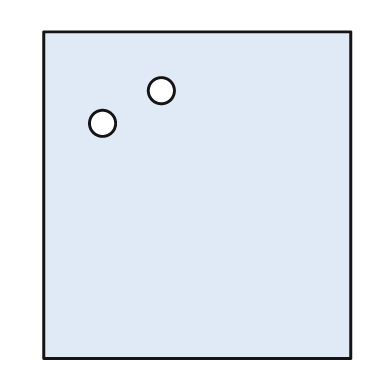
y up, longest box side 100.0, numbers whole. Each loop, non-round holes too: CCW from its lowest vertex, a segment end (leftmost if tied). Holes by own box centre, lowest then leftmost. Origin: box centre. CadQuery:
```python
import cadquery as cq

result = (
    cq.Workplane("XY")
    .moveTo(-47.0, -50.0)
    .lineTo(47.0, -50.0)
    .lineTo(47.0, 50.0)
    .lineTo(-47.0, 50.0)
    .close()
    .moveTo(-29.0, 22.0)
    .circle(4.0)
    .moveTo(-11.0, 32.0)
    .circle(4.0)
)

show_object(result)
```